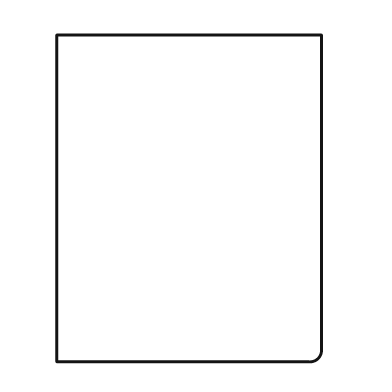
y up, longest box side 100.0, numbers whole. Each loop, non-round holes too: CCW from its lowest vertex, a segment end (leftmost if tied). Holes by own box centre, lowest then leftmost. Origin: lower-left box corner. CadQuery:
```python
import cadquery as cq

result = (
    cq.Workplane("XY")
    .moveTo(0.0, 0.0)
    .lineTo(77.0, 0.0)
    .threePointArc((80.0, 1.0), (81.0, 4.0))
    .lineTo(81.0, 100.0)
    .lineTo(0.0, 100.0)
    .close()
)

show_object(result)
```